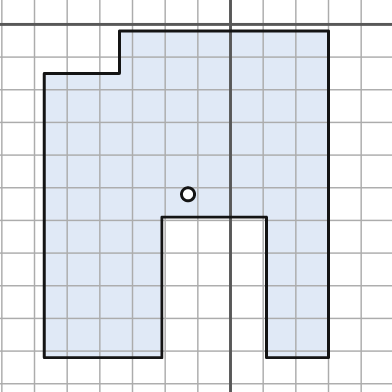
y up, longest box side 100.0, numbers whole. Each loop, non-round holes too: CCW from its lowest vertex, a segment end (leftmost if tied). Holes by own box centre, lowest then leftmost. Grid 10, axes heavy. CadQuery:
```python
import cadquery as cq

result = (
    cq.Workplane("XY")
    .moveTo(-57.0, -102.0)
    .lineTo(-21.0, -102.0)
    .lineTo(-21.0, -59.0)
    .lineTo(11.0, -59.0)
    .lineTo(11.0, -102.0)
    .lineTo(30.0, -102.0)
    .lineTo(30.0, -2.0)
    .lineTo(-34.0, -2.0)
    .lineTo(-34.0, -15.0)
    .lineTo(-57.0, -15.0)
    .close()
    .moveTo(-13.0, -52.0)
    .circle(2.0)
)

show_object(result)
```